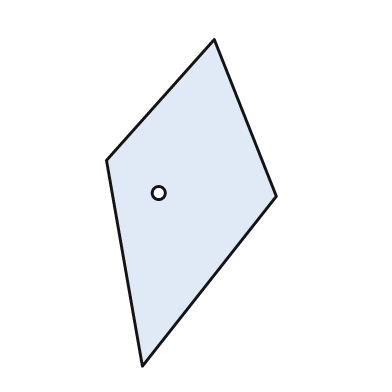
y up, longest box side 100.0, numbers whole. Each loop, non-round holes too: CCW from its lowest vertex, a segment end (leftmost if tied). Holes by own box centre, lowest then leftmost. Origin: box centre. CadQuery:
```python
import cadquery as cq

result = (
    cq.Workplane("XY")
    .moveTo(-15.0, -50.0)
    .lineTo(26.0, 2.0)
    .lineTo(7.0, 50.0)
    .lineTo(-26.0, 13.0)
    .close()
    .moveTo(-10.0, 3.0)
    .circle(2.0)
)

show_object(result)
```